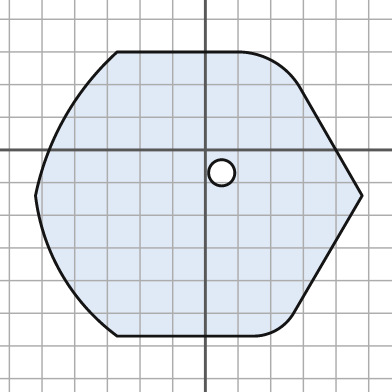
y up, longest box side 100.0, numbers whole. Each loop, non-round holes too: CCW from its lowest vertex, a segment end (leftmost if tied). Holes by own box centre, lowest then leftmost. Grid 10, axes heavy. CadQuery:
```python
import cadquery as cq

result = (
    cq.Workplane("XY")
    .moveTo(-27.0, -57.0)
    .lineTo(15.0, -57.0)
    .threePointArc((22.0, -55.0), (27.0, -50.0))
    .lineTo(48.0, -14.0)
    .lineTo(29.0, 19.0)
    .threePointArc((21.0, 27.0), (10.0, 30.0))
    .lineTo(-27.0, 30.0)
    .threePointArc((-43.0, 10.0), (-52.0, -14.0))
    .threePointArc((-44.0, -38.0), (-27.0, -57.0))
    .close()
    .moveTo(5.0, -7.0)
    .circle(4.0)
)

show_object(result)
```